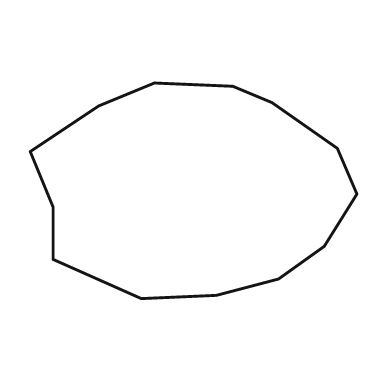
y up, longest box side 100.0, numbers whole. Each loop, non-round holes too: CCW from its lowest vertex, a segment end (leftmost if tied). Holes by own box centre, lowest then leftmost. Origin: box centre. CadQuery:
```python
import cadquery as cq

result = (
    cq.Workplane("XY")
    .moveTo(-16.0, -33.0)
    .lineTo(7.0, -32.0)
    .lineTo(26.0, -27.0)
    .lineTo(40.0, -17.0)
    .lineTo(50.0, -1.0)
    .lineTo(44.0, 13.0)
    .lineTo(24.0, 27.0)
    .lineTo(12.0, 32.0)
    .lineTo(-12.0, 33.0)
    .lineTo(-29.0, 26.0)
    .lineTo(-50.0, 12.0)
    .lineTo(-43.0, -5.0)
    .lineTo(-43.0, -21.0)
    .close()
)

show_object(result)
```